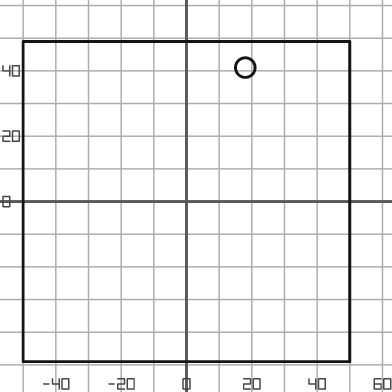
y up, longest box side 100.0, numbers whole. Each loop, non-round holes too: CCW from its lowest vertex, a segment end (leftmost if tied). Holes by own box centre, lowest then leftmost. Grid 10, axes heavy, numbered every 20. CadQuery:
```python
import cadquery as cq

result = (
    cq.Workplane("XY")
    .moveTo(-50.0, -49.0)
    .lineTo(50.0, -49.0)
    .lineTo(50.0, 49.0)
    .lineTo(-50.0, 49.0)
    .close()
    .moveTo(18.0, 41.0)
    .circle(3.0)
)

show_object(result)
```